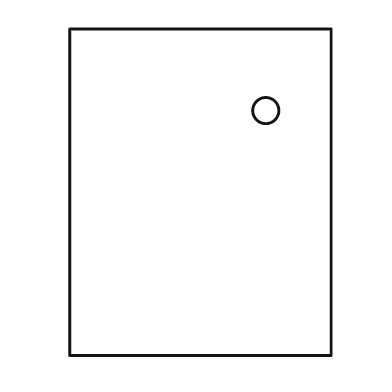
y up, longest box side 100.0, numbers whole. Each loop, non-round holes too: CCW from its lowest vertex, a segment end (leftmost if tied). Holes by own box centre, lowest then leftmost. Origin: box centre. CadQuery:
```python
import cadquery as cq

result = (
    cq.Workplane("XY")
    .moveTo(-40.0, -50.0)
    .lineTo(40.0, -50.0)
    .lineTo(40.0, 50.0)
    .lineTo(-40.0, 50.0)
    .close()
    .moveTo(20.0, 25.0)
    .circle(4.0)
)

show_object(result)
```